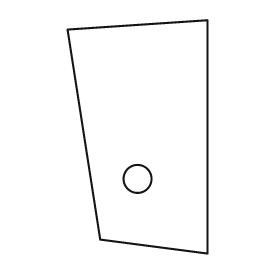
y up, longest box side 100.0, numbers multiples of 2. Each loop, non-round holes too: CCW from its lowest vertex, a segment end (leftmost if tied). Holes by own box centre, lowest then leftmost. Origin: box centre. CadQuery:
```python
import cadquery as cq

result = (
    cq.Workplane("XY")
    .moveTo(30.0, -50.0)
    .lineTo(30.0, 50.0)
    .lineTo(-30.0, 46.0)
    .lineTo(-16.0, -44.0)
    .close()
    .moveTo(0.0, -18.0)
    .circle(6.0)
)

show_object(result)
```